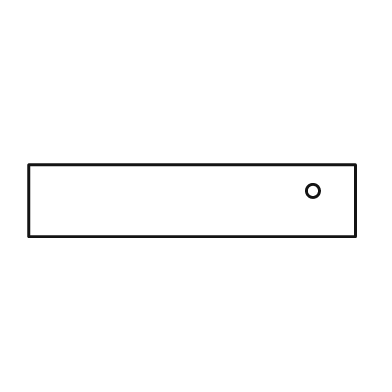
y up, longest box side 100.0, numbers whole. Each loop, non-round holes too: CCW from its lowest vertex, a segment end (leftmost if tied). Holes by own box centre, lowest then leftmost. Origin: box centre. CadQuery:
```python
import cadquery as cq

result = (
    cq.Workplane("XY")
    .moveTo(-50.0, -11.0)
    .lineTo(50.0, -11.0)
    .lineTo(50.0, 11.0)
    .lineTo(-50.0, 11.0)
    .close()
    .moveTo(37.0, 3.0)
    .circle(2.0)
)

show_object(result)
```